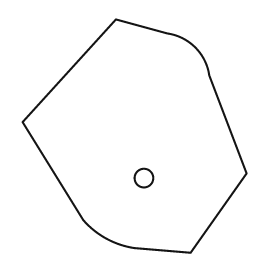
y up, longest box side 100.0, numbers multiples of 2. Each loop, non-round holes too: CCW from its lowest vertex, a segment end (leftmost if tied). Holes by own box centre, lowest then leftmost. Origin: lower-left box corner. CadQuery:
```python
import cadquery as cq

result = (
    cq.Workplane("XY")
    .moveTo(72.0, 0.0)
    .lineTo(96.0, 34.0)
    .lineTo(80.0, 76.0)
    .threePointArc((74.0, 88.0), (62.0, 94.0))
    .lineTo(40.0, 100.0)
    .lineTo(0.0, 56.0)
    .lineTo(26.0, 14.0)
    .threePointArc((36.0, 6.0), (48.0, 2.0))
    .close()
    .moveTo(52.0, 32.0)
    .circle(4.0)
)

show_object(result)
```